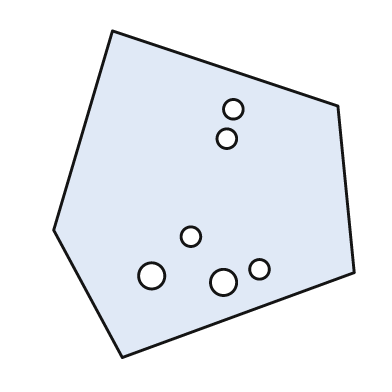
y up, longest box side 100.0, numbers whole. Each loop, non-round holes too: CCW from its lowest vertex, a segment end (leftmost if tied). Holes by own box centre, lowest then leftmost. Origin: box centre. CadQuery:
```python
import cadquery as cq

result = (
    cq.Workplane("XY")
    .moveTo(-25.0, -50.0)
    .lineTo(46.0, -24.0)
    .lineTo(41.0, 27.0)
    .lineTo(-28.0, 50.0)
    .lineTo(-46.0, -11.0)
    .close()
    .moveTo(6.0, -27.0)
    .circle(4.0)
    .moveTo(-16.0, -25.0)
    .circle(4.0)
    .moveTo(17.0, -23.0)
    .circle(3.0)
    .moveTo(-4.0, -13.0)
    .circle(3.0)
    .moveTo(7.0, 17.0)
    .circle(3.0)
    .moveTo(9.0, 26.0)
    .circle(3.0)
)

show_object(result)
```